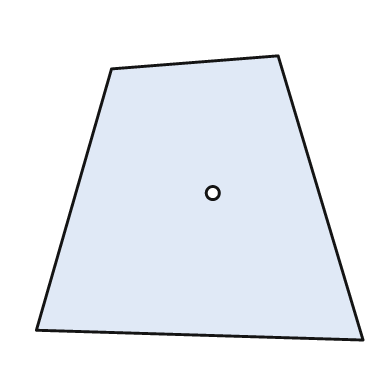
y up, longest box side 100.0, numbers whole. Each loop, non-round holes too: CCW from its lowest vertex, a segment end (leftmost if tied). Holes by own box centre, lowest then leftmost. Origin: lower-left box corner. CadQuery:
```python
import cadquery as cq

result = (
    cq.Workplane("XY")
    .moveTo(100.0, 0.0)
    .lineTo(74.0, 87.0)
    .lineTo(23.0, 83.0)
    .lineTo(0.0, 3.0)
    .close()
    .moveTo(54.0, 45.0)
    .circle(2.0)
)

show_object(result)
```